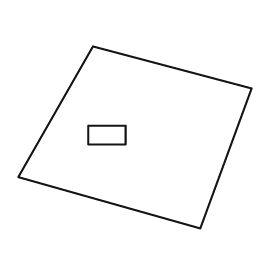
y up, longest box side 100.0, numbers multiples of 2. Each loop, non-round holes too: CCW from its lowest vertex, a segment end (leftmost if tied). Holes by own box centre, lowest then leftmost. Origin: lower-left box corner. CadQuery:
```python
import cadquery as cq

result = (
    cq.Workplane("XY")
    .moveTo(78.0, 0.0)
    .lineTo(100.0, 60.0)
    .lineTo(32.0, 78.0)
    .lineTo(0.0, 22.0)
    .close()
    .moveTo(30.0, 36.0)
    .lineTo(46.0, 36.0)
    .lineTo(46.0, 44.0)
    .lineTo(30.0, 44.0)
    .close()
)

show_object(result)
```